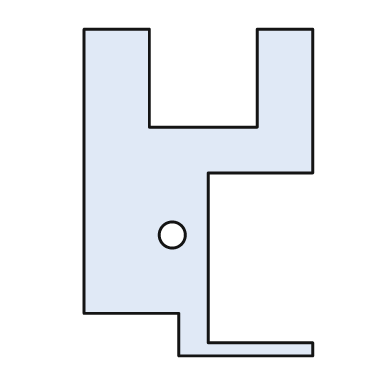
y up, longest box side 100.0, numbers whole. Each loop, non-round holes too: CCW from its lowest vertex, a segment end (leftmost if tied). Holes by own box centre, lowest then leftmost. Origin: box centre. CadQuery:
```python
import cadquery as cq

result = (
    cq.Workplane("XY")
    .moveTo(-6.0, -50.0)
    .lineTo(35.0, -50.0)
    .lineTo(35.0, -46.0)
    .lineTo(3.0, -46.0)
    .lineTo(3.0, 6.0)
    .lineTo(35.0, 6.0)
    .lineTo(35.0, 50.0)
    .lineTo(18.0, 50.0)
    .lineTo(18.0, 20.0)
    .lineTo(-15.0, 20.0)
    .lineTo(-15.0, 50.0)
    .lineTo(-35.0, 50.0)
    .lineTo(-35.0, -37.0)
    .lineTo(-6.0, -37.0)
    .close()
    .moveTo(-8.0, -13.0)
    .circle(4.0)
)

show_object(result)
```